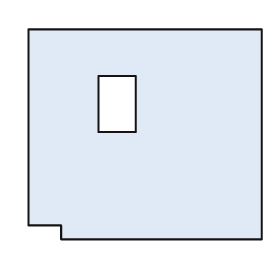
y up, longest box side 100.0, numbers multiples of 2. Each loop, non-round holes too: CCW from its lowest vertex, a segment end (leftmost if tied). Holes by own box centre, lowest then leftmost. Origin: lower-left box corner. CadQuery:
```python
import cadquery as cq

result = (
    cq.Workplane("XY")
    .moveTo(14.0, 0.0)
    .lineTo(100.0, 0.0)
    .lineTo(100.0, 90.0)
    .lineTo(0.0, 90.0)
    .lineTo(0.0, 6.0)
    .lineTo(14.0, 6.0)
    .close()
    .moveTo(30.0, 46.0)
    .lineTo(46.0, 46.0)
    .lineTo(46.0, 70.0)
    .lineTo(30.0, 70.0)
    .close()
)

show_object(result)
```